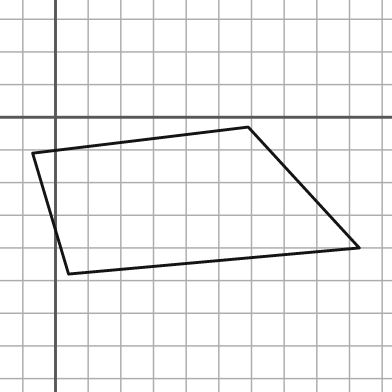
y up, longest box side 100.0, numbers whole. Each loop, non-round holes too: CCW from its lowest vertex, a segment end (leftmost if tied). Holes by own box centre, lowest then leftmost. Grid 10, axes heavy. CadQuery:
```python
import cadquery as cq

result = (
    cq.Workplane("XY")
    .moveTo(4.0, -48.0)
    .lineTo(93.0, -40.0)
    .lineTo(59.0, -3.0)
    .lineTo(-7.0, -11.0)
    .close()
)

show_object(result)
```